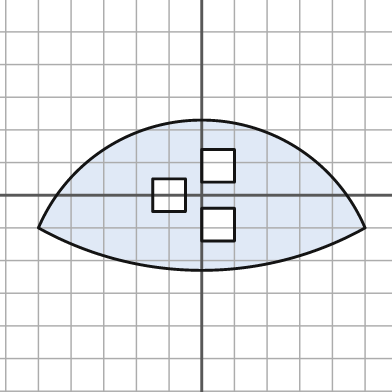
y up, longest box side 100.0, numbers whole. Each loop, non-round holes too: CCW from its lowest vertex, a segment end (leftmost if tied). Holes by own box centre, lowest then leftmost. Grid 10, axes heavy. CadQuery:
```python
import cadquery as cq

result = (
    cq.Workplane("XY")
    .moveTo(-50.0, -10.0)
    .threePointArc((0.0, -23.0), (50.0, -10.0))
    .threePointArc((0.0, 23.0), (-50.0, -10.0))
    .close()
    .moveTo(0.0, -14.0)
    .lineTo(10.0, -14.0)
    .lineTo(10.0, -4.0)
    .lineTo(0.0, -4.0)
    .close()
    .moveTo(-15.0, -5.0)
    .lineTo(-5.0, -5.0)
    .lineTo(-5.0, 5.0)
    .lineTo(-15.0, 5.0)
    .close()
    .moveTo(0.0, 4.0)
    .lineTo(10.0, 4.0)
    .lineTo(10.0, 14.0)
    .lineTo(0.0, 14.0)
    .close()
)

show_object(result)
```